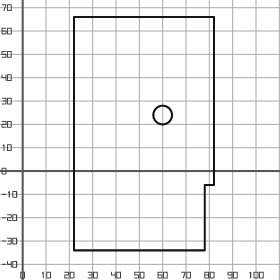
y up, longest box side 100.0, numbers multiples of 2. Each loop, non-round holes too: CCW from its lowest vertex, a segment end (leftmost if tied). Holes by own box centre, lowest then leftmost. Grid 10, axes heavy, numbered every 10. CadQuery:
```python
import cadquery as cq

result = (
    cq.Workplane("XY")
    .moveTo(22.0, -34.0)
    .lineTo(78.0, -34.0)
    .lineTo(78.0, -6.0)
    .lineTo(82.0, -6.0)
    .lineTo(82.0, 66.0)
    .lineTo(22.0, 66.0)
    .close()
    .moveTo(60.0, 24.0)
    .circle(4.0)
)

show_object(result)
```